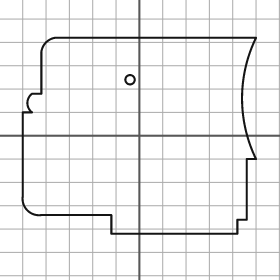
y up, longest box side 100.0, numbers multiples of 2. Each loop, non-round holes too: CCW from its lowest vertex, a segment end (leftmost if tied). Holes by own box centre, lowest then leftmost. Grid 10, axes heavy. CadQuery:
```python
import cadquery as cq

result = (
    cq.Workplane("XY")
    .moveTo(-12.0, -42.0)
    .lineTo(42.0, -42.0)
    .lineTo(42.0, -36.0)
    .lineTo(46.0, -36.0)
    .lineTo(46.0, -10.0)
    .lineTo(50.0, -10.0)
    .threePointArc((44.0, 16.0), (50.0, 42.0))
    .lineTo(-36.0, 42.0)
    .threePointArc((-40.0, 40.0), (-42.0, 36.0))
    .lineTo(-42.0, 18.0)
    .lineTo(-46.0, 18.0)
    .threePointArc((-48.0, 14.0), (-46.0, 10.0))
    .lineTo(-50.0, 10.0)
    .lineTo(-50.0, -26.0)
    .threePointArc((-48.0, -32.0), (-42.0, -34.0))
    .lineTo(-12.0, -34.0)
    .close()
    .moveTo(-4.0, 24.0)
    .circle(2.0)
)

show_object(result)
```